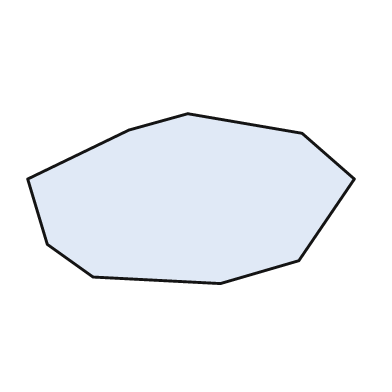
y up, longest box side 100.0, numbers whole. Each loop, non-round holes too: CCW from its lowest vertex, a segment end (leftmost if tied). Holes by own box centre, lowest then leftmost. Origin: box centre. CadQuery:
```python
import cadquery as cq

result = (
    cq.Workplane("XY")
    .moveTo(9.0, -26.0)
    .lineTo(33.0, -19.0)
    .lineTo(50.0, 6.0)
    .lineTo(34.0, 20.0)
    .lineTo(-1.0, 26.0)
    .lineTo(-19.0, 21.0)
    .lineTo(-50.0, 6.0)
    .lineTo(-44.0, -14.0)
    .lineTo(-30.0, -24.0)
    .close()
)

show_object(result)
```